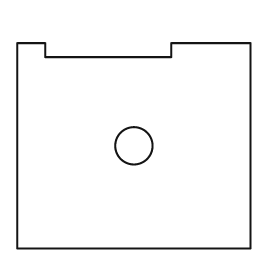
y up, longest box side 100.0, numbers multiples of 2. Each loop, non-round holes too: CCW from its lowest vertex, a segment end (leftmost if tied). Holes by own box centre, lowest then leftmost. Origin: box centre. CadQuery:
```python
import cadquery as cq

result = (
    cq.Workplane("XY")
    .moveTo(-50.0, -44.0)
    .lineTo(50.0, -44.0)
    .lineTo(50.0, 44.0)
    .lineTo(16.0, 44.0)
    .lineTo(16.0, 38.0)
    .lineTo(-38.0, 38.0)
    .lineTo(-38.0, 44.0)
    .lineTo(-50.0, 44.0)
    .close()
    .moveTo(0.0, 0.0)
    .circle(8.0)
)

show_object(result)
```